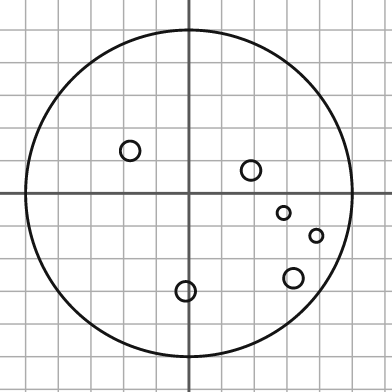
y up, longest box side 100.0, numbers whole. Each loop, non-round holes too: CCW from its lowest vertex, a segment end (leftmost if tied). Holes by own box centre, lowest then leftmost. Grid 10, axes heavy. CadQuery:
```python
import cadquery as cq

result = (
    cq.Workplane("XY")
    .moveTo(0.0, 0.0)
    .circle(50.0)
    .moveTo(-1.0, -30.0)
    .circle(3.0)
    .moveTo(32.0, -26.0)
    .circle(3.0)
    .moveTo(39.0, -13.0)
    .circle(2.0)
    .moveTo(29.0, -6.0)
    .circle(2.0)
    .moveTo(19.0, 7.0)
    .circle(3.0)
    .moveTo(-18.0, 13.0)
    .circle(3.0)
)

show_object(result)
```